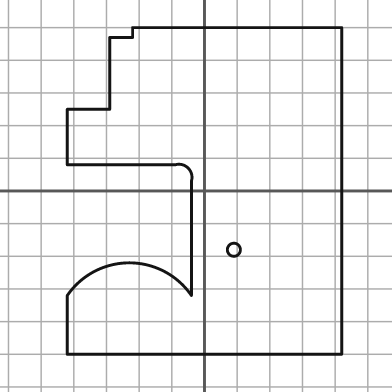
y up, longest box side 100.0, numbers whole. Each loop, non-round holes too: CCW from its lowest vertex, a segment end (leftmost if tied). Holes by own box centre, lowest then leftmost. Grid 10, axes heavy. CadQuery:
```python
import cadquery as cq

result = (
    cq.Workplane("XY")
    .moveTo(-42.0, -50.0)
    .lineTo(42.0, -50.0)
    .lineTo(42.0, 50.0)
    .lineTo(-22.0, 50.0)
    .lineTo(-22.0, 47.0)
    .lineTo(-29.0, 47.0)
    .lineTo(-29.0, 25.0)
    .lineTo(-42.0, 25.0)
    .lineTo(-42.0, 8.0)
    .lineTo(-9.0, 8.0)
    .threePointArc((-5.0, 7.0), (-4.0, 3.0))
    .lineTo(-4.0, -32.0)
    .threePointArc((-23.0, -22.0), (-42.0, -32.0))
    .close()
    .moveTo(9.0, -18.0)
    .circle(2.0)
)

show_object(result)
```